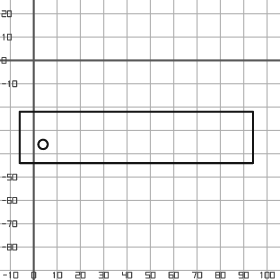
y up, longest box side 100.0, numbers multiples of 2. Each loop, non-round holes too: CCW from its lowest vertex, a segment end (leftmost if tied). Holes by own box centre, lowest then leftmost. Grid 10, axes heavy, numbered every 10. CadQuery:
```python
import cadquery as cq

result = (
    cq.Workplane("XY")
    .moveTo(-6.0, -44.0)
    .lineTo(94.0, -44.0)
    .lineTo(94.0, -22.0)
    .lineTo(-6.0, -22.0)
    .close()
    .moveTo(4.0, -36.0)
    .circle(2.0)
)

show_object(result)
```